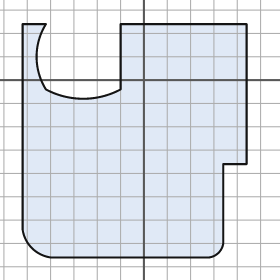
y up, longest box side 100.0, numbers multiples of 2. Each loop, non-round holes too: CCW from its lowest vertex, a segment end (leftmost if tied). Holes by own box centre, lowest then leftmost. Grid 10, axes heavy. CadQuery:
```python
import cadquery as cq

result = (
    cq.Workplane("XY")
    .moveTo(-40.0, -76.0)
    .lineTo(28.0, -76.0)
    .threePointArc((32.0, -74.0), (34.0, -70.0))
    .lineTo(34.0, -36.0)
    .lineTo(44.0, -36.0)
    .lineTo(44.0, 24.0)
    .lineTo(-10.0, 24.0)
    .lineTo(-10.0, -4.0)
    .threePointArc((-26.0, -8.0), (-42.0, -4.0))
    .threePointArc((-46.0, 10.0), (-42.0, 24.0))
    .lineTo(-52.0, 24.0)
    .lineTo(-52.0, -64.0)
    .threePointArc((-48.0, -72.0), (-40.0, -76.0))
    .close()
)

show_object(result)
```